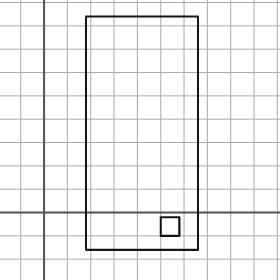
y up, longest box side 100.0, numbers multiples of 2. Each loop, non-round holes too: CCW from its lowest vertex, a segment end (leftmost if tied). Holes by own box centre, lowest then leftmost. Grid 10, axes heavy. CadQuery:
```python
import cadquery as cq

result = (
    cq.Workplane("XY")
    .moveTo(18.0, -16.0)
    .lineTo(66.0, -16.0)
    .lineTo(66.0, 84.0)
    .lineTo(18.0, 84.0)
    .close()
    .moveTo(50.0, -10.0)
    .lineTo(58.0, -10.0)
    .lineTo(58.0, -2.0)
    .lineTo(50.0, -2.0)
    .close()
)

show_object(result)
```